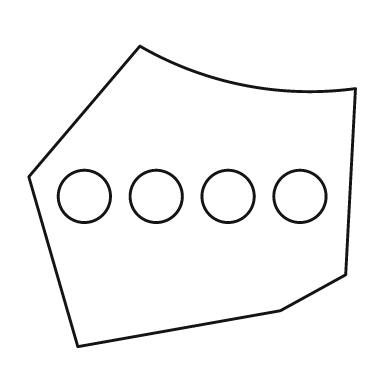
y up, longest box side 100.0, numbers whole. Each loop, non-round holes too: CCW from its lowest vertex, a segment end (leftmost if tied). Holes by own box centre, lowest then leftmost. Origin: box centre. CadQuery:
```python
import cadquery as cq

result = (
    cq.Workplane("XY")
    .moveTo(-35.0, -46.0)
    .lineTo(27.0, -35.0)
    .lineTo(47.0, -24.0)
    .lineTo(50.0, 33.0)
    .threePointArc((16.0, 34.0), (-16.0, 46.0))
    .lineTo(-50.0, 6.0)
    .close()
    .moveTo(-33.0, 0.0)
    .circle(8.0)
    .moveTo(-11.0, 0.0)
    .circle(8.0)
    .moveTo(11.0, 0.0)
    .circle(8.0)
    .moveTo(33.0, 0.0)
    .circle(8.0)
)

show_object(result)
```